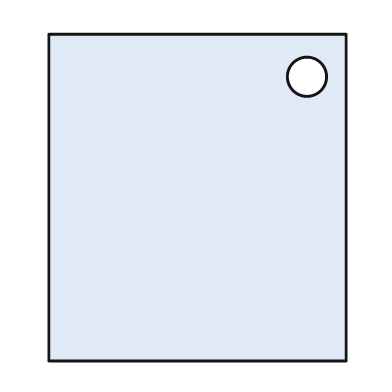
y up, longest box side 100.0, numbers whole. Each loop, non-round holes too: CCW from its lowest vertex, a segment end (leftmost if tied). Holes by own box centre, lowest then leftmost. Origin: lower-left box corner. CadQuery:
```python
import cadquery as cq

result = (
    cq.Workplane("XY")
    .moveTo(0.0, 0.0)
    .lineTo(91.0, 0.0)
    .lineTo(91.0, 100.0)
    .lineTo(0.0, 100.0)
    .close()
    .moveTo(79.0, 87.0)
    .circle(6.0)
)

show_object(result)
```